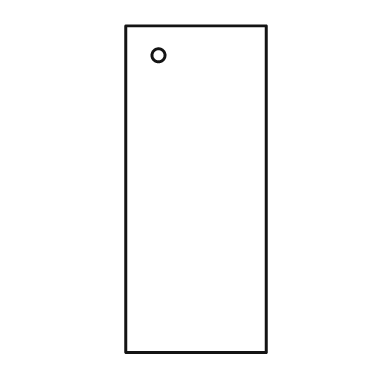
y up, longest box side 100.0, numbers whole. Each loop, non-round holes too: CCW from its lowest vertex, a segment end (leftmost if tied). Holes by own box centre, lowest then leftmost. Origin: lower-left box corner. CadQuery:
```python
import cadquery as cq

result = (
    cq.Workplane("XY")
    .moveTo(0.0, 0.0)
    .lineTo(43.0, 0.0)
    .lineTo(43.0, 100.0)
    .lineTo(0.0, 100.0)
    .close()
    .moveTo(10.0, 91.0)
    .circle(2.0)
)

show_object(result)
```